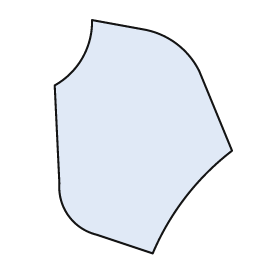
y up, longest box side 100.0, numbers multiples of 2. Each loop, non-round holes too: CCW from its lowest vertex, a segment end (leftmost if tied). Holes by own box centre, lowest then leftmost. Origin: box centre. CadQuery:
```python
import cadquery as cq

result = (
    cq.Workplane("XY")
    .moveTo(4.0, -50.0)
    .threePointArc((18.0, -26.0), (38.0, -6.0))
    .lineTo(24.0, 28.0)
    .threePointArc((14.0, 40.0), (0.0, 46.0))
    .lineTo(-22.0, 50.0)
    .threePointArc((-26.0, 34.0), (-38.0, 22.0))
    .lineTo(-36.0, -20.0)
    .threePointArc((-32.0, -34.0), (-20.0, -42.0))
    .close()
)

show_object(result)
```